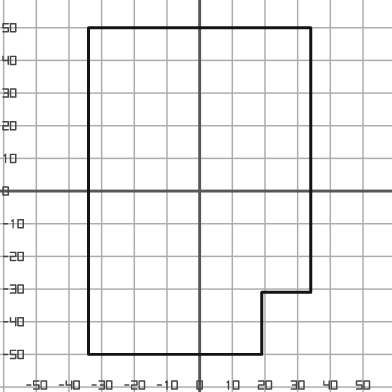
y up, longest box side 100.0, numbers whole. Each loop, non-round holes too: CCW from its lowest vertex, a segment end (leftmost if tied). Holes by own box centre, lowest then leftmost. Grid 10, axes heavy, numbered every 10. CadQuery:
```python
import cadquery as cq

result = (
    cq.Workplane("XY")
    .moveTo(-34.0, -50.0)
    .lineTo(19.0, -50.0)
    .lineTo(19.0, -31.0)
    .lineTo(34.0, -31.0)
    .lineTo(34.0, 50.0)
    .lineTo(-34.0, 50.0)
    .close()
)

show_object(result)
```